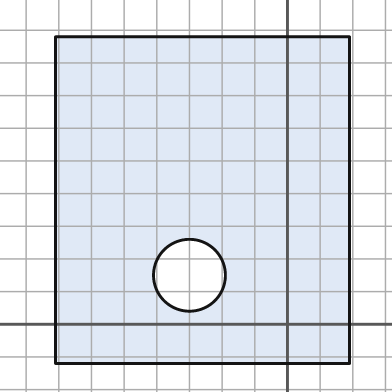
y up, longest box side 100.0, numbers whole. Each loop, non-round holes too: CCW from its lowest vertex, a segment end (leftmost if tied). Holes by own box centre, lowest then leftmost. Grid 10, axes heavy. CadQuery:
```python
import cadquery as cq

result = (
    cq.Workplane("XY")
    .moveTo(-71.0, -12.0)
    .lineTo(19.0, -12.0)
    .lineTo(19.0, 88.0)
    .lineTo(-71.0, 88.0)
    .close()
    .moveTo(-30.0, 15.0)
    .circle(11.0)
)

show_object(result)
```